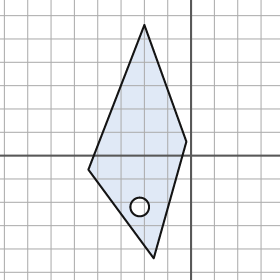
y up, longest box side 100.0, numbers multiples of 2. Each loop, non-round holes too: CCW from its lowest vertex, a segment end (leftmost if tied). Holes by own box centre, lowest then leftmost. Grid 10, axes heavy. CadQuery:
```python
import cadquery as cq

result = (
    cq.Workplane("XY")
    .moveTo(-16.0, -44.0)
    .lineTo(-2.0, 6.0)
    .lineTo(-20.0, 56.0)
    .lineTo(-44.0, -6.0)
    .close()
    .moveTo(-22.0, -22.0)
    .circle(4.0)
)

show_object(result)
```